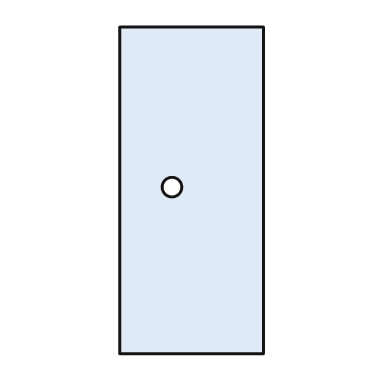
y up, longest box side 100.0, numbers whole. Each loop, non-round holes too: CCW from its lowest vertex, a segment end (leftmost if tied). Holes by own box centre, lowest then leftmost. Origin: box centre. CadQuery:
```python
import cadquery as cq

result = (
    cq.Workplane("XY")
    .moveTo(-22.0, -50.0)
    .lineTo(22.0, -50.0)
    .lineTo(22.0, 50.0)
    .lineTo(-22.0, 50.0)
    .close()
    .moveTo(-6.0, 1.0)
    .circle(3.0)
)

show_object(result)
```